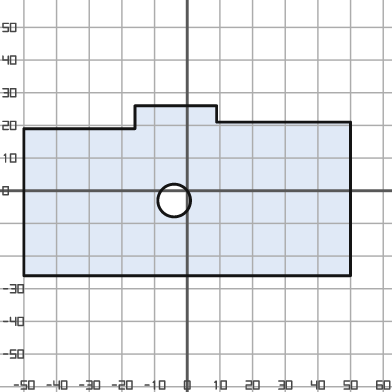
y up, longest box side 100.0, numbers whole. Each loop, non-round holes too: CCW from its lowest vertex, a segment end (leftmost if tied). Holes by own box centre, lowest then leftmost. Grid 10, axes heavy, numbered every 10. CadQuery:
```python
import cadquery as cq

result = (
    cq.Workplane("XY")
    .moveTo(-50.0, -26.0)
    .lineTo(50.0, -26.0)
    .lineTo(50.0, 21.0)
    .lineTo(9.0, 21.0)
    .lineTo(9.0, 26.0)
    .lineTo(-16.0, 26.0)
    .lineTo(-16.0, 19.0)
    .lineTo(-50.0, 19.0)
    .close()
    .moveTo(-4.0, -3.0)
    .circle(5.0)
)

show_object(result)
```